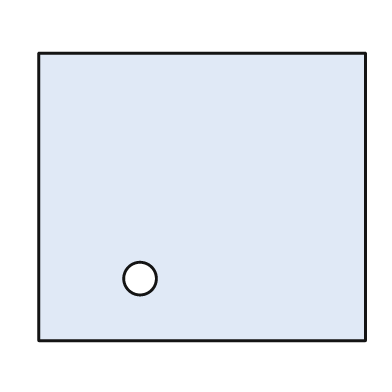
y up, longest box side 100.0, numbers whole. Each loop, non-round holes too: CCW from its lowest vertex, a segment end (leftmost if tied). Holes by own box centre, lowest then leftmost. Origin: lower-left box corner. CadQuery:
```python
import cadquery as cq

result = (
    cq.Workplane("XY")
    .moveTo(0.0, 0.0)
    .lineTo(100.0, 0.0)
    .lineTo(100.0, 88.0)
    .lineTo(0.0, 88.0)
    .close()
    .moveTo(31.0, 19.0)
    .circle(5.0)
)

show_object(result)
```